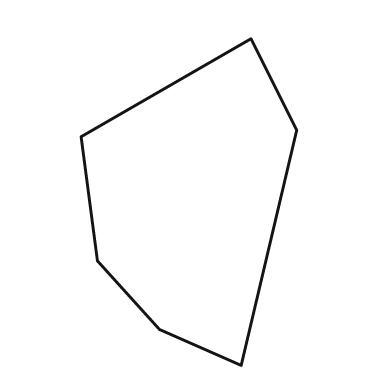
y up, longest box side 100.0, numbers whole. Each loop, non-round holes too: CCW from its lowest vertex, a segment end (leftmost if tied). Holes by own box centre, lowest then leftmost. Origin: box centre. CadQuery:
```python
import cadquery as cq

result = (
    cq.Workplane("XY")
    .moveTo(16.0, -50.0)
    .lineTo(33.0, 22.0)
    .lineTo(19.0, 50.0)
    .lineTo(-33.0, 20.0)
    .lineTo(-28.0, -18.0)
    .lineTo(-9.0, -39.0)
    .close()
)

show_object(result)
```